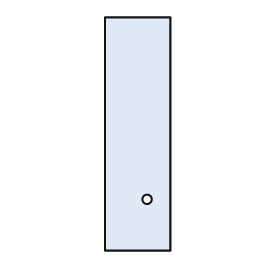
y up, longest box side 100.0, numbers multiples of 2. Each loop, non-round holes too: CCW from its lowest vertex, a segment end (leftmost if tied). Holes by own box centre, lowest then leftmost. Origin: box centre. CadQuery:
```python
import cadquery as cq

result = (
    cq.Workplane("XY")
    .moveTo(-14.0, -50.0)
    .lineTo(14.0, -50.0)
    .lineTo(14.0, 50.0)
    .lineTo(-14.0, 50.0)
    .close()
    .moveTo(4.0, -28.0)
    .circle(2.0)
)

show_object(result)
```